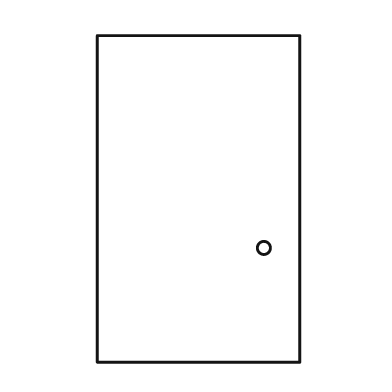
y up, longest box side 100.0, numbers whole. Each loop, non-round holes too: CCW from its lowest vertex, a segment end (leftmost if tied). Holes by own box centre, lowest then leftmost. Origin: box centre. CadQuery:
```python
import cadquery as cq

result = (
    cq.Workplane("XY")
    .moveTo(-31.0, -50.0)
    .lineTo(31.0, -50.0)
    .lineTo(31.0, 50.0)
    .lineTo(-31.0, 50.0)
    .close()
    .moveTo(20.0, -15.0)
    .circle(2.0)
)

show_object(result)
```